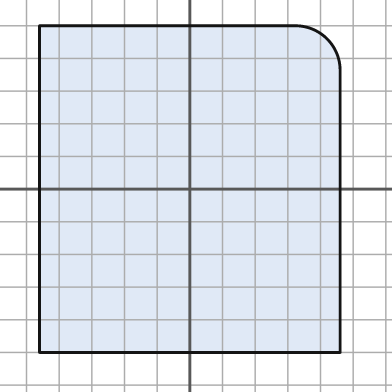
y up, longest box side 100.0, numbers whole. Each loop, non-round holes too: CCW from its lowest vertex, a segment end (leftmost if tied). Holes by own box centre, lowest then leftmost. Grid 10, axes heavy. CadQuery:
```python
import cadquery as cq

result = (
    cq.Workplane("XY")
    .moveTo(-46.0, -50.0)
    .lineTo(46.0, -50.0)
    .lineTo(46.0, 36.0)
    .threePointArc((42.0, 46.0), (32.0, 50.0))
    .lineTo(-46.0, 50.0)
    .close()
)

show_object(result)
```